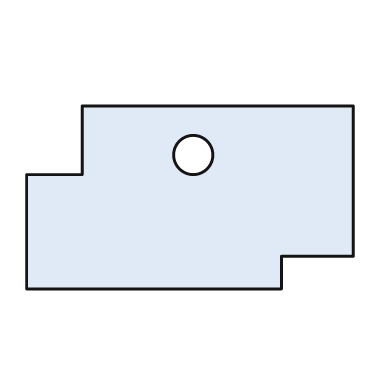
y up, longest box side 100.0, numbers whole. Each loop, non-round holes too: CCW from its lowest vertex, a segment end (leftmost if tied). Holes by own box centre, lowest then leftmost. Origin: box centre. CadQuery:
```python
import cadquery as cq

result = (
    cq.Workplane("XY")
    .moveTo(-50.0, -28.0)
    .lineTo(28.0, -28.0)
    .lineTo(28.0, -18.0)
    .lineTo(50.0, -18.0)
    .lineTo(50.0, 28.0)
    .lineTo(-33.0, 28.0)
    .lineTo(-33.0, 7.0)
    .lineTo(-50.0, 7.0)
    .close()
    .moveTo(1.0, 13.0)
    .circle(6.0)
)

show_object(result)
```